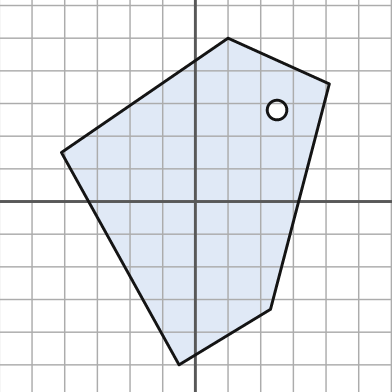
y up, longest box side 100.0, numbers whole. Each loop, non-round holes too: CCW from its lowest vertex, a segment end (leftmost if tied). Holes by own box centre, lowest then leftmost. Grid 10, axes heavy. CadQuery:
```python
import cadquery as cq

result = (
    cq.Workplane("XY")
    .moveTo(-5.0, -50.0)
    .lineTo(23.0, -33.0)
    .lineTo(41.0, 36.0)
    .lineTo(10.0, 50.0)
    .lineTo(-41.0, 15.0)
    .close()
    .moveTo(25.0, 28.0)
    .circle(3.0)
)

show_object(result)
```